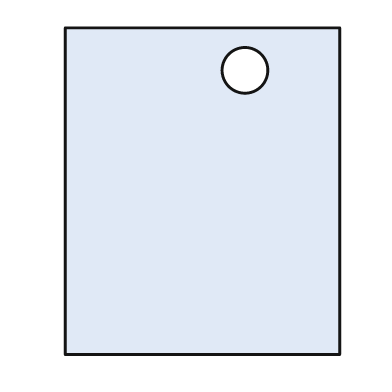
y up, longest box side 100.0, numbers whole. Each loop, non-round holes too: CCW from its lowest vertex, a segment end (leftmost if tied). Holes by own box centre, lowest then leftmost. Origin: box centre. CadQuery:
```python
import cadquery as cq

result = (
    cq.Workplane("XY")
    .moveTo(-42.0, -50.0)
    .lineTo(42.0, -50.0)
    .lineTo(42.0, 50.0)
    .lineTo(-42.0, 50.0)
    .close()
    .moveTo(13.0, 37.0)
    .circle(7.0)
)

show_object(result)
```